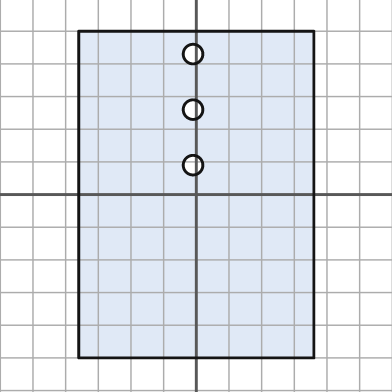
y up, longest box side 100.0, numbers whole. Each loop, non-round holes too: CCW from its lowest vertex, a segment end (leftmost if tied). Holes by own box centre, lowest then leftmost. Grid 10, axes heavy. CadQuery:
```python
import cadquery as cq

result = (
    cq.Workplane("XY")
    .moveTo(-36.0, -50.0)
    .lineTo(36.0, -50.0)
    .lineTo(36.0, 50.0)
    .lineTo(-36.0, 50.0)
    .close()
    .moveTo(-1.0, 9.0)
    .circle(3.0)
    .moveTo(-1.0, 26.0)
    .circle(3.0)
    .moveTo(-1.0, 43.0)
    .circle(3.0)
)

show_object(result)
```